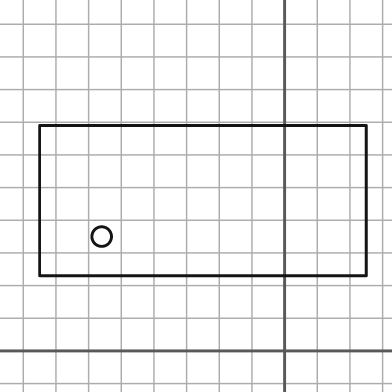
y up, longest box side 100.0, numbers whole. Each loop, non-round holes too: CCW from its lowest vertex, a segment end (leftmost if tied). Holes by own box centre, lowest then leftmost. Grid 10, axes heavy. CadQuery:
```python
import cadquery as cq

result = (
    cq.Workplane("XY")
    .moveTo(-75.0, 23.0)
    .lineTo(25.0, 23.0)
    .lineTo(25.0, 69.0)
    .lineTo(-75.0, 69.0)
    .close()
    .moveTo(-56.0, 35.0)
    .circle(3.0)
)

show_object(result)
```